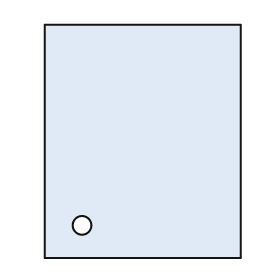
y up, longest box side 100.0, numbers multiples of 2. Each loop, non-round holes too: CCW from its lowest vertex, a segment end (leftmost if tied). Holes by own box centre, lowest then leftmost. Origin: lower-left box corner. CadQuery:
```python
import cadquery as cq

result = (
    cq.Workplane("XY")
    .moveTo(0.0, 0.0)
    .lineTo(84.0, 0.0)
    .lineTo(84.0, 100.0)
    .lineTo(0.0, 100.0)
    .close()
    .moveTo(16.0, 14.0)
    .circle(4.0)
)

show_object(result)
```